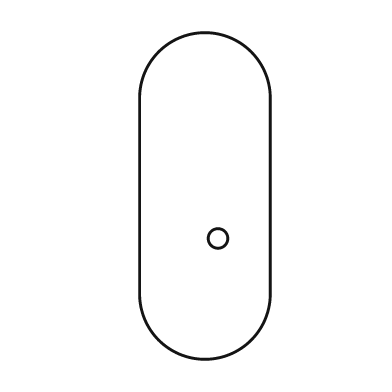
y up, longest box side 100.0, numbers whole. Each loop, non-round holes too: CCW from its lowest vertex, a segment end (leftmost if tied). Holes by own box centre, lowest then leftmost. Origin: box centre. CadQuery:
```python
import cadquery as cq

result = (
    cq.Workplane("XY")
    .moveTo(-20.0, -30.0)
    .threePointArc((0.0, -50.0), (20.0, -30.0))
    .lineTo(20.0, 30.0)
    .threePointArc((0.0, 50.0), (-20.0, 30.0))
    .close()
    .moveTo(4.0, -13.0)
    .circle(3.0)
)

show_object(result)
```